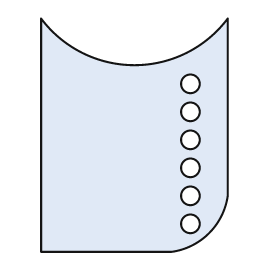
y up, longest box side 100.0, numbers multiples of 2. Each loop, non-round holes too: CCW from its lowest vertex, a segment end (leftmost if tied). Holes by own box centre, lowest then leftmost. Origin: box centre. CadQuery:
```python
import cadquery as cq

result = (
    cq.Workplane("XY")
    .moveTo(-40.0, -50.0)
    .lineTo(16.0, -50.0)
    .threePointArc((32.0, -42.0), (40.0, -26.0))
    .lineTo(40.0, 50.0)
    .threePointArc((0.0, 30.0), (-40.0, 50.0))
    .close()
    .moveTo(24.0, -38.0)
    .circle(4.0)
    .moveTo(24.0, -26.0)
    .circle(4.0)
    .moveTo(24.0, -14.0)
    .circle(4.0)
    .moveTo(24.0, -2.0)
    .circle(4.0)
    .moveTo(24.0, 10.0)
    .circle(4.0)
    .moveTo(24.0, 22.0)
    .circle(4.0)
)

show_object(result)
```